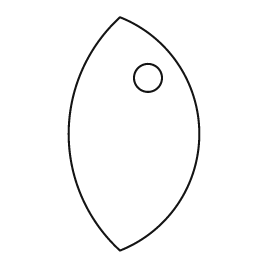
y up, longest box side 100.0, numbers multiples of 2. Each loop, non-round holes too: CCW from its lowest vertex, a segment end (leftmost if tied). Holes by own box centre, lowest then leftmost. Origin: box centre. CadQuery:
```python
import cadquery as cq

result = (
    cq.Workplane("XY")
    .moveTo(-6.0, -50.0)
    .threePointArc((28.0, 0.0), (-6.0, 50.0))
    .threePointArc((-28.0, 0.0), (-6.0, -50.0))
    .close()
    .moveTo(6.0, 24.0)
    .circle(6.0)
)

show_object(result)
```